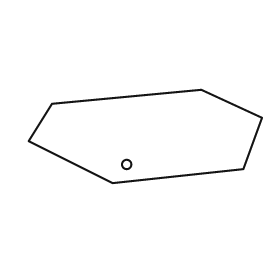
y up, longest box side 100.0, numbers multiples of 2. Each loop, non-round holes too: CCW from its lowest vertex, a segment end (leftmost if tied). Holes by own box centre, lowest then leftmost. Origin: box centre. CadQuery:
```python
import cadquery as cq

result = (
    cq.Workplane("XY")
    .moveTo(-14.0, -20.0)
    .lineTo(42.0, -14.0)
    .lineTo(50.0, 8.0)
    .lineTo(24.0, 20.0)
    .lineTo(-40.0, 14.0)
    .lineTo(-50.0, -2.0)
    .close()
    .moveTo(-8.0, -12.0)
    .circle(2.0)
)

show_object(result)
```